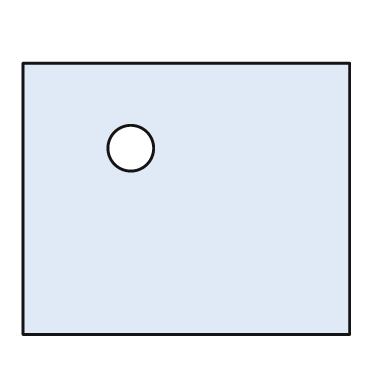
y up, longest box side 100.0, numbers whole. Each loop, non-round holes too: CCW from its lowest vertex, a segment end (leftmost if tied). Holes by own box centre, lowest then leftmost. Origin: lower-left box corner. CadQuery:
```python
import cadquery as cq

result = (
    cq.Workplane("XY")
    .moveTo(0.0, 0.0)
    .lineTo(100.0, 0.0)
    .lineTo(100.0, 83.0)
    .lineTo(0.0, 83.0)
    .close()
    .moveTo(33.0, 57.0)
    .circle(7.0)
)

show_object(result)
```